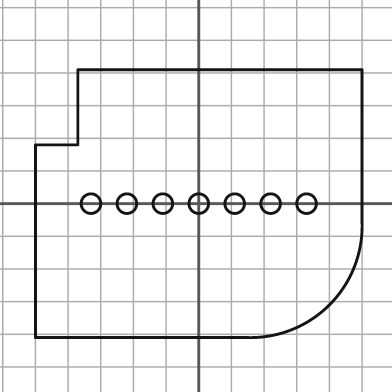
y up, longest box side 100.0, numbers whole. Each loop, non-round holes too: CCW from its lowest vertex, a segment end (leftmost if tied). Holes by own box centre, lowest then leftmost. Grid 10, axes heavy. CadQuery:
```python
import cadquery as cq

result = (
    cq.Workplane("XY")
    .moveTo(-50.0, -41.0)
    .lineTo(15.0, -41.0)
    .threePointArc((40.0, -31.0), (50.0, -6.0))
    .lineTo(50.0, 41.0)
    .lineTo(-37.0, 41.0)
    .lineTo(-37.0, 18.0)
    .lineTo(-50.0, 18.0)
    .close()
    .moveTo(-33.0, 0.0)
    .circle(3.0)
    .moveTo(-22.0, 0.0)
    .circle(3.0)
    .moveTo(-11.0, 0.0)
    .circle(3.0)
    .moveTo(0.0, 0.0)
    .circle(3.0)
    .moveTo(11.0, 0.0)
    .circle(3.0)
    .moveTo(22.0, 0.0)
    .circle(3.0)
    .moveTo(33.0, 0.0)
    .circle(3.0)
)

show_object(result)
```